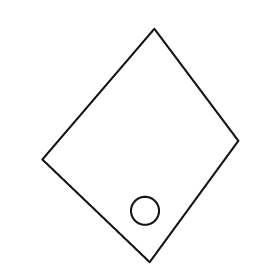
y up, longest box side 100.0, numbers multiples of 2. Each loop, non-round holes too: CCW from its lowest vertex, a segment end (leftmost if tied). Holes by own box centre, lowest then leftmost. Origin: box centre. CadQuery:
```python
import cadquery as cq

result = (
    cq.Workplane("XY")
    .moveTo(4.0, -50.0)
    .lineTo(42.0, 2.0)
    .lineTo(6.0, 50.0)
    .lineTo(-42.0, -6.0)
    .close()
    .moveTo(2.0, -28.0)
    .circle(6.0)
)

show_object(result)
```